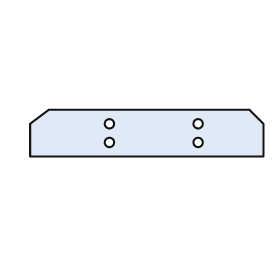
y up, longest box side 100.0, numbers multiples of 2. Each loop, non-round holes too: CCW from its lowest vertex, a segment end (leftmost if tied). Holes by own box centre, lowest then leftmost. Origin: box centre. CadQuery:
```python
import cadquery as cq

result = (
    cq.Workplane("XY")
    .moveTo(-50.0, -10.0)
    .lineTo(50.0, -10.0)
    .lineTo(50.0, 4.0)
    .lineTo(44.0, 10.0)
    .lineTo(-42.0, 10.0)
    .lineTo(-50.0, 4.0)
    .close()
    .moveTo(-16.0, -4.0)
    .circle(2.0)
    .moveTo(22.0, -4.0)
    .circle(2.0)
    .moveTo(-16.0, 4.0)
    .circle(2.0)
    .moveTo(22.0, 4.0)
    .circle(2.0)
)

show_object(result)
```